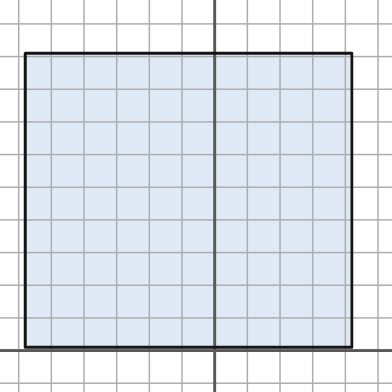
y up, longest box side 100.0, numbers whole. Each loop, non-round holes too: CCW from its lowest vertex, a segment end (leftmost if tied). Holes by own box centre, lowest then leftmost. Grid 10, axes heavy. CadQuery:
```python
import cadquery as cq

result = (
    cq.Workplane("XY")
    .moveTo(-58.0, 1.0)
    .lineTo(42.0, 1.0)
    .lineTo(42.0, 91.0)
    .lineTo(-58.0, 91.0)
    .close()
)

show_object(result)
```